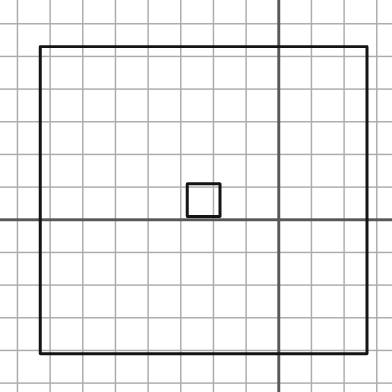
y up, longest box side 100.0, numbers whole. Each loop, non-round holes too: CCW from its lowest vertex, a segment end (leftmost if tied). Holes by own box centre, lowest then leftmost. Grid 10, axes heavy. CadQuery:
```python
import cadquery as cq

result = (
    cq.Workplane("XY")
    .moveTo(-73.0, -41.0)
    .lineTo(27.0, -41.0)
    .lineTo(27.0, 53.0)
    .lineTo(-73.0, 53.0)
    .close()
    .moveTo(-28.0, 1.0)
    .lineTo(-18.0, 1.0)
    .lineTo(-18.0, 11.0)
    .lineTo(-28.0, 11.0)
    .close()
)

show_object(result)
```